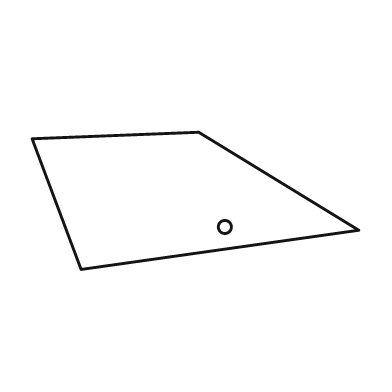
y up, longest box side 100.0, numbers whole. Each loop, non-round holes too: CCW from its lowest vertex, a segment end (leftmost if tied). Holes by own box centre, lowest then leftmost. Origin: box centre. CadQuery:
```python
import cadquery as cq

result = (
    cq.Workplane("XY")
    .moveTo(-35.0, -21.0)
    .lineTo(50.0, -9.0)
    .lineTo(1.0, 21.0)
    .lineTo(-50.0, 19.0)
    .close()
    .moveTo(9.0, -8.0)
    .circle(2.0)
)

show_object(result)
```